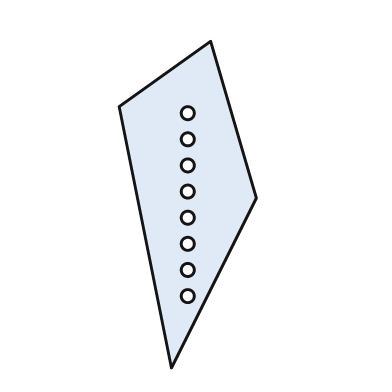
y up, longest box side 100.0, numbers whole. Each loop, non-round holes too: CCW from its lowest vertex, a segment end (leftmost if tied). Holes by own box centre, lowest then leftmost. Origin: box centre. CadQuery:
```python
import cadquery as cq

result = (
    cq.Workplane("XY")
    .moveTo(-5.0, -50.0)
    .lineTo(21.0, 2.0)
    .lineTo(7.0, 50.0)
    .lineTo(-21.0, 30.0)
    .close()
    .moveTo(0.0, -28.0)
    .circle(2.0)
    .moveTo(0.0, -20.0)
    .circle(2.0)
    .moveTo(0.0, -12.0)
    .circle(2.0)
    .moveTo(0.0, -4.0)
    .circle(2.0)
    .moveTo(0.0, 4.0)
    .circle(2.0)
    .moveTo(0.0, 12.0)
    .circle(2.0)
    .moveTo(0.0, 20.0)
    .circle(2.0)
    .moveTo(0.0, 28.0)
    .circle(2.0)
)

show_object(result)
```